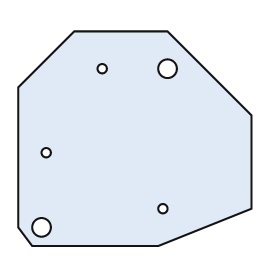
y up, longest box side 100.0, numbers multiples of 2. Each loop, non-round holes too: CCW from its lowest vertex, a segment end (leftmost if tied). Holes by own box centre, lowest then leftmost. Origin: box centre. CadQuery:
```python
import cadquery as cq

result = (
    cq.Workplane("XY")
    .moveTo(-44.0, -46.0)
    .lineTo(10.0, -46.0)
    .lineTo(50.0, -30.0)
    .lineTo(50.0, 10.0)
    .lineTo(14.0, 46.0)
    .lineTo(-26.0, 46.0)
    .lineTo(-50.0, 22.0)
    .lineTo(-50.0, -38.0)
    .close()
    .moveTo(-40.0, -38.0)
    .circle(4.0)
    .moveTo(12.0, -30.0)
    .circle(2.0)
    .moveTo(-38.0, -6.0)
    .circle(2.0)
    .moveTo(-14.0, 30.0)
    .circle(2.0)
    .moveTo(14.0, 30.0)
    .circle(4.0)
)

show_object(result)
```